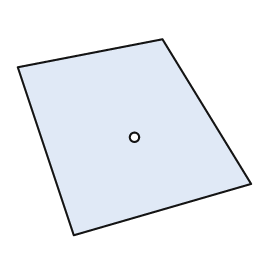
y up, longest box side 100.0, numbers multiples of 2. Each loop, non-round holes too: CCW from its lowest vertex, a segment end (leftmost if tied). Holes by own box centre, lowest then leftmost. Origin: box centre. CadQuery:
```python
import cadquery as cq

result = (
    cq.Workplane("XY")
    .moveTo(-26.0, -42.0)
    .lineTo(50.0, -20.0)
    .lineTo(12.0, 42.0)
    .lineTo(-50.0, 30.0)
    .close()
    .moveTo(0.0, 0.0)
    .circle(2.0)
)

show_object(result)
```